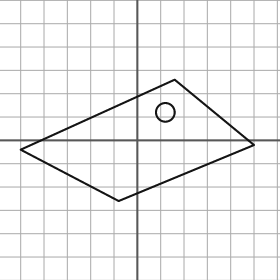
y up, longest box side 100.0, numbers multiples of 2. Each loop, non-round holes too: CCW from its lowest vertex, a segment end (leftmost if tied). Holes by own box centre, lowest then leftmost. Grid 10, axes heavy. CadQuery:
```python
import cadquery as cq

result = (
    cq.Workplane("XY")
    .moveTo(-8.0, -26.0)
    .lineTo(50.0, -2.0)
    .lineTo(16.0, 26.0)
    .lineTo(-50.0, -4.0)
    .close()
    .moveTo(12.0, 12.0)
    .circle(4.0)
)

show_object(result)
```